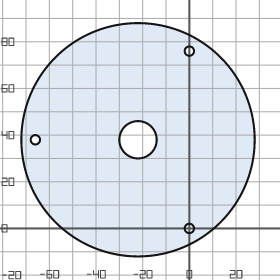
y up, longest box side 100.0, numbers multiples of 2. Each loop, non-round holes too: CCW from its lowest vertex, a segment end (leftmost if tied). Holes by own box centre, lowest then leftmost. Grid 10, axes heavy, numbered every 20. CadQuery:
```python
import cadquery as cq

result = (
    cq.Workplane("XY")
    .moveTo(-22.0, 38.0)
    .circle(50.0)
    .moveTo(0.0, 0.0)
    .circle(2.0)
    .moveTo(-66.0, 38.0)
    .circle(2.0)
    .moveTo(-22.0, 38.0)
    .circle(8.0)
    .moveTo(0.0, 76.0)
    .circle(2.0)
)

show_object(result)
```